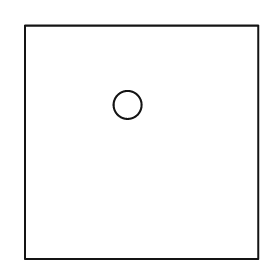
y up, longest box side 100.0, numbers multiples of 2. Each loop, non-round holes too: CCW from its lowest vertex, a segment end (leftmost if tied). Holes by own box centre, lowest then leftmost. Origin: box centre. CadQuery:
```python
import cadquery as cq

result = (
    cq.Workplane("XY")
    .moveTo(-50.0, -50.0)
    .lineTo(50.0, -50.0)
    .lineTo(50.0, 50.0)
    .lineTo(-50.0, 50.0)
    .close()
    .moveTo(-6.0, 16.0)
    .circle(6.0)
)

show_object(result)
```